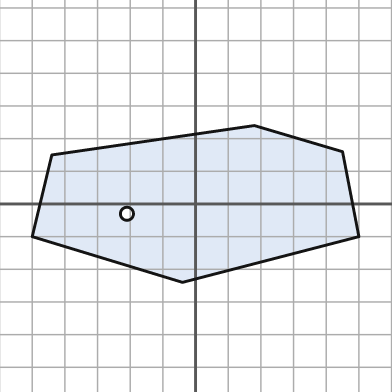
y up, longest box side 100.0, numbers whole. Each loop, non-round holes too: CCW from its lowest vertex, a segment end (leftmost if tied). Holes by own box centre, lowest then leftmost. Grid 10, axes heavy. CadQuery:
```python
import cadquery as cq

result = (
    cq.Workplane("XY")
    .moveTo(-4.0, -24.0)
    .lineTo(50.0, -10.0)
    .lineTo(45.0, 16.0)
    .lineTo(18.0, 24.0)
    .lineTo(-44.0, 15.0)
    .lineTo(-50.0, -10.0)
    .close()
    .moveTo(-21.0, -3.0)
    .circle(2.0)
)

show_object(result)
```